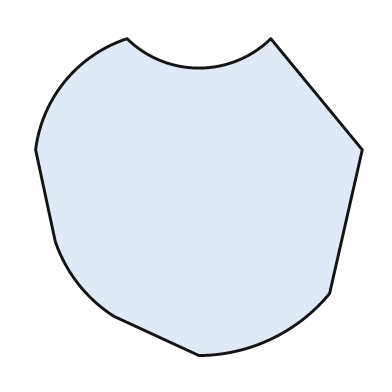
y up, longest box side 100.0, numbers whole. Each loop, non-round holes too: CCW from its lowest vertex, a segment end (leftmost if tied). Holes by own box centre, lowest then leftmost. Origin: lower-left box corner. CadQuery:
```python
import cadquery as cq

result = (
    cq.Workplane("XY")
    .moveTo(50.0, 0.0)
    .threePointArc((72.0, 5.0), (90.0, 19.0))
    .lineTo(100.0, 63.0)
    .lineTo(72.0, 97.0)
    .threePointArc((50.0, 88.0), (28.0, 97.0))
    .threePointArc((9.0, 84.0), (0.0, 63.0))
    .lineTo(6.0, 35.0)
    .threePointArc((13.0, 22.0), (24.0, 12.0))
    .close()
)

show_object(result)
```